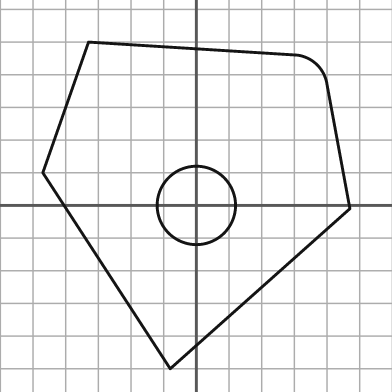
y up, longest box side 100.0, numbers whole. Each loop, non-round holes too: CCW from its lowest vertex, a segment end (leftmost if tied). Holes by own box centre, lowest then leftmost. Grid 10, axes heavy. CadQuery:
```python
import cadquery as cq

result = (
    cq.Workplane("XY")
    .moveTo(-8.0, -50.0)
    .lineTo(47.0, -1.0)
    .lineTo(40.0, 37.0)
    .threePointArc((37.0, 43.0), (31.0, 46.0))
    .lineTo(-33.0, 50.0)
    .lineTo(-47.0, 10.0)
    .close()
    .moveTo(0.0, 0.0)
    .circle(12.0)
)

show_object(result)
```